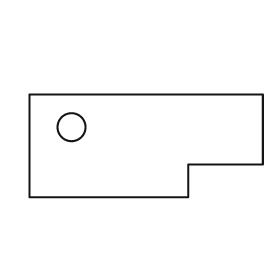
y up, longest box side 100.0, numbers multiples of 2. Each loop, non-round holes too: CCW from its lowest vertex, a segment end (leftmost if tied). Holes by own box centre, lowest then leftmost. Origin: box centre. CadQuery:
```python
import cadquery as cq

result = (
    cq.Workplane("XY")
    .moveTo(-50.0, -22.0)
    .lineTo(18.0, -22.0)
    .lineTo(18.0, -8.0)
    .lineTo(50.0, -8.0)
    .lineTo(50.0, 22.0)
    .lineTo(-50.0, 22.0)
    .close()
    .moveTo(-32.0, 8.0)
    .circle(6.0)
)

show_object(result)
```